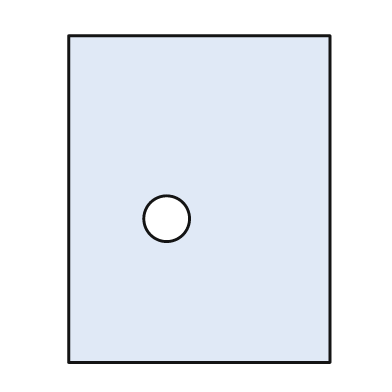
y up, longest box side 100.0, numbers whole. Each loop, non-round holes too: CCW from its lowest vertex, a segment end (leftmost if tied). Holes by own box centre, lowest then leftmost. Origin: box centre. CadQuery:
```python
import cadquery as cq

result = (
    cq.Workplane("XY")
    .moveTo(-40.0, -50.0)
    .lineTo(40.0, -50.0)
    .lineTo(40.0, 50.0)
    .lineTo(-40.0, 50.0)
    .close()
    .moveTo(-10.0, -6.0)
    .circle(7.0)
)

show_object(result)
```